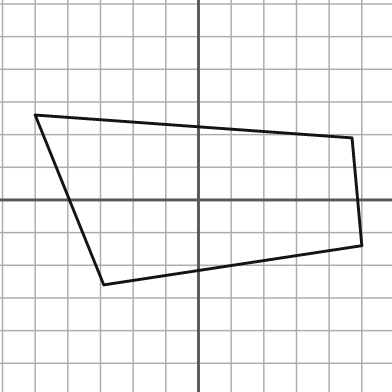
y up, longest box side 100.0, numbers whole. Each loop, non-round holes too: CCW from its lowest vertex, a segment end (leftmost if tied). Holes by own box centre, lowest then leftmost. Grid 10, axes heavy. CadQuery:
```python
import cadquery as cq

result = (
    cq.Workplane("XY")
    .moveTo(-29.0, -26.0)
    .lineTo(50.0, -14.0)
    .lineTo(47.0, 19.0)
    .lineTo(-50.0, 26.0)
    .close()
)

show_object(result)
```